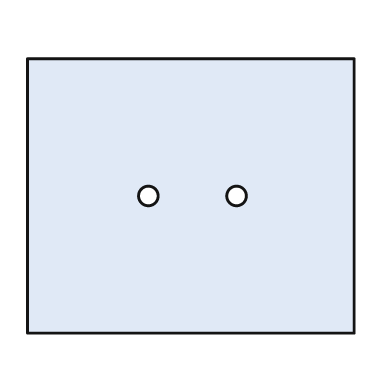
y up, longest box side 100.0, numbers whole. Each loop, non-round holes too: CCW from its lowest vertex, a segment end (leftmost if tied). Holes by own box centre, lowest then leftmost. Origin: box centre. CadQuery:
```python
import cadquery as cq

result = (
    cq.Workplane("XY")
    .moveTo(-50.0, -42.0)
    .lineTo(50.0, -42.0)
    .lineTo(50.0, 42.0)
    .lineTo(-50.0, 42.0)
    .close()
    .moveTo(-13.0, 0.0)
    .circle(3.0)
    .moveTo(14.0, 0.0)
    .circle(3.0)
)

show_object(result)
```